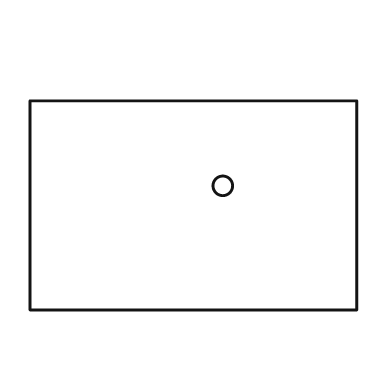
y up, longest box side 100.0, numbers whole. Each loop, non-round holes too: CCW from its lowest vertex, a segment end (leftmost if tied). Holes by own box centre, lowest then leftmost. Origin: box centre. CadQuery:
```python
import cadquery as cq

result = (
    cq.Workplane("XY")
    .moveTo(-50.0, -32.0)
    .lineTo(50.0, -32.0)
    .lineTo(50.0, 32.0)
    .lineTo(-50.0, 32.0)
    .close()
    .moveTo(9.0, 6.0)
    .circle(3.0)
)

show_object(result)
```